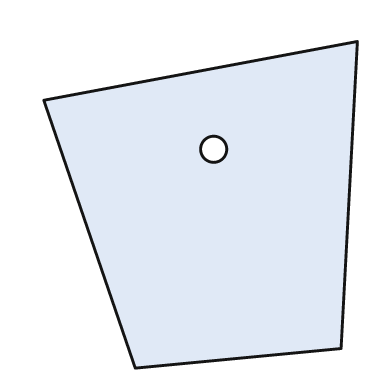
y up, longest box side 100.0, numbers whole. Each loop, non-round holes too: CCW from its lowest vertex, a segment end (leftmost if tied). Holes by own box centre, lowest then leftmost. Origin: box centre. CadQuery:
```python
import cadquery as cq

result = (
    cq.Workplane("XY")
    .moveTo(-20.0, -50.0)
    .lineTo(43.0, -44.0)
    .lineTo(48.0, 50.0)
    .lineTo(-48.0, 32.0)
    .close()
    .moveTo(4.0, 17.0)
    .circle(4.0)
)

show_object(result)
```